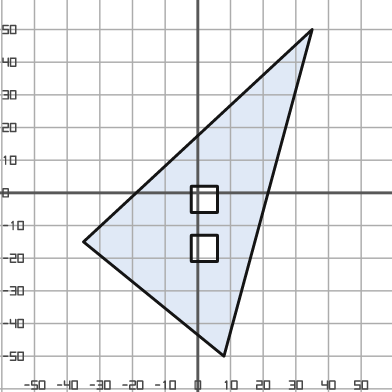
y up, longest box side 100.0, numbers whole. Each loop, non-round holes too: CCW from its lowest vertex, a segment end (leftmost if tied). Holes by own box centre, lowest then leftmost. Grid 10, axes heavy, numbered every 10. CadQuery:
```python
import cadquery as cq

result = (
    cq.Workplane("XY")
    .moveTo(8.0, -50.0)
    .lineTo(35.0, 50.0)
    .lineTo(-35.0, -15.0)
    .close()
    .moveTo(-2.0, -21.0)
    .lineTo(6.0, -21.0)
    .lineTo(6.0, -13.0)
    .lineTo(-2.0, -13.0)
    .close()
    .moveTo(-2.0, -6.0)
    .lineTo(6.0, -6.0)
    .lineTo(6.0, 2.0)
    .lineTo(-2.0, 2.0)
    .close()
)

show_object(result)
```